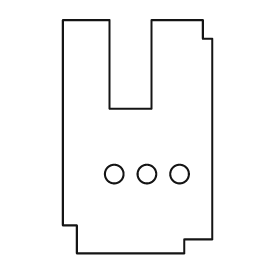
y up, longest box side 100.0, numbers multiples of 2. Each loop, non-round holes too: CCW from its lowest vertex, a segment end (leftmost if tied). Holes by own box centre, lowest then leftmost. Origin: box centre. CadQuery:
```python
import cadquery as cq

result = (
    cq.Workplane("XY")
    .moveTo(-26.0, -50.0)
    .lineTo(20.0, -50.0)
    .lineTo(20.0, -44.0)
    .lineTo(32.0, -44.0)
    .lineTo(32.0, 42.0)
    .lineTo(28.0, 42.0)
    .lineTo(28.0, 50.0)
    .lineTo(6.0, 50.0)
    .lineTo(6.0, 12.0)
    .lineTo(-12.0, 12.0)
    .lineTo(-12.0, 50.0)
    .lineTo(-32.0, 50.0)
    .lineTo(-32.0, -38.0)
    .lineTo(-26.0, -38.0)
    .close()
    .moveTo(-10.0, -16.0)
    .circle(4.0)
    .moveTo(4.0, -16.0)
    .circle(4.0)
    .moveTo(18.0, -16.0)
    .circle(4.0)
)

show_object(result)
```